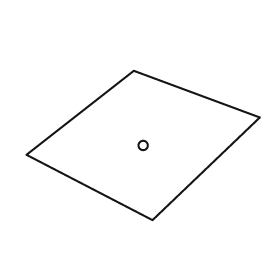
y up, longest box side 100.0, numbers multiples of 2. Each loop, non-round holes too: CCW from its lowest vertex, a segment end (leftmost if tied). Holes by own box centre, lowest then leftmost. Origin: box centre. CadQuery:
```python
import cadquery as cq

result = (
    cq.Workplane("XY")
    .moveTo(4.0, -32.0)
    .lineTo(50.0, 12.0)
    .lineTo(-4.0, 32.0)
    .lineTo(-50.0, -4.0)
    .close()
    .moveTo(0.0, 0.0)
    .circle(2.0)
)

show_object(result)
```